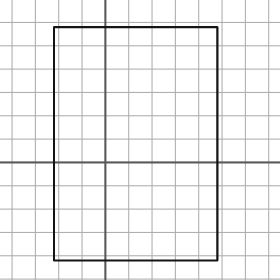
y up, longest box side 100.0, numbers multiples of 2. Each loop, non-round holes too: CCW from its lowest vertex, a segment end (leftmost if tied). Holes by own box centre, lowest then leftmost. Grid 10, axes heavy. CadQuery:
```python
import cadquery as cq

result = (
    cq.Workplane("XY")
    .moveTo(-22.0, -42.0)
    .lineTo(48.0, -42.0)
    .lineTo(48.0, 58.0)
    .lineTo(-22.0, 58.0)
    .close()
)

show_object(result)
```